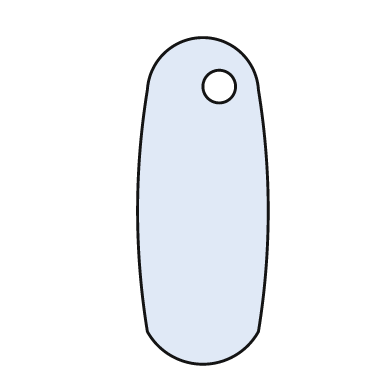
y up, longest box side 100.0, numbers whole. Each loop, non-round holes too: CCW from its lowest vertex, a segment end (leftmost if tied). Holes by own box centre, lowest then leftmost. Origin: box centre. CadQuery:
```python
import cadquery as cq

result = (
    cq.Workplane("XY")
    .moveTo(-17.0, -40.0)
    .threePointArc((0.0, -50.0), (17.0, -40.0))
    .threePointArc((20.0, -3.0), (17.0, 34.0))
    .threePointArc((0.0, 50.0), (-17.0, 34.0))
    .threePointArc((-20.0, -3.0), (-17.0, -40.0))
    .close()
    .moveTo(5.0, 35.0)
    .circle(5.0)
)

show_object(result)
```